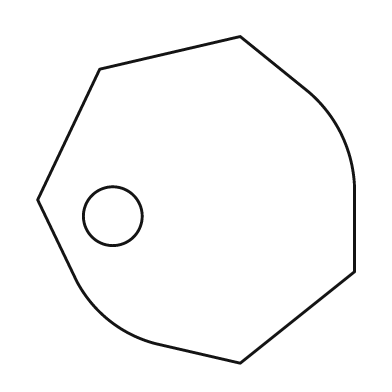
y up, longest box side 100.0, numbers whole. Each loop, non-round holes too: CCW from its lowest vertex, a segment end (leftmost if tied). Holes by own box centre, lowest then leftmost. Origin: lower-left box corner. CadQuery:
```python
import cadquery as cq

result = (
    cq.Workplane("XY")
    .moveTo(62.0, 0.0)
    .lineTo(97.0, 28.0)
    .lineTo(97.0, 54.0)
    .threePointArc((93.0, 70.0), (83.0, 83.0))
    .lineTo(62.0, 100.0)
    .lineTo(19.0, 90.0)
    .lineTo(0.0, 50.0)
    .lineTo(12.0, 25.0)
    .threePointArc((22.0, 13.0), (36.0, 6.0))
    .close()
    .moveTo(23.0, 45.0)
    .circle(9.0)
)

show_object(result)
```